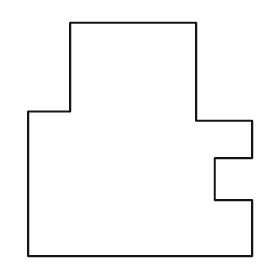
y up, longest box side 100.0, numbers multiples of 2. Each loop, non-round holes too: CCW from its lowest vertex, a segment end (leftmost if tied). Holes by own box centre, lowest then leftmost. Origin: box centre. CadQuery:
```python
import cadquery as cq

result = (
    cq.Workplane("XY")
    .moveTo(-48.0, -50.0)
    .lineTo(48.0, -50.0)
    .lineTo(48.0, -26.0)
    .lineTo(32.0, -26.0)
    .lineTo(32.0, -8.0)
    .lineTo(48.0, -8.0)
    .lineTo(48.0, 8.0)
    .lineTo(24.0, 8.0)
    .lineTo(24.0, 50.0)
    .lineTo(-30.0, 50.0)
    .lineTo(-30.0, 12.0)
    .lineTo(-48.0, 12.0)
    .close()
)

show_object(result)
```